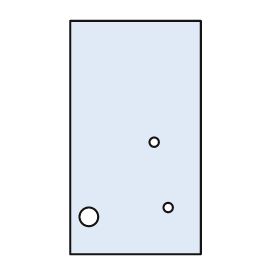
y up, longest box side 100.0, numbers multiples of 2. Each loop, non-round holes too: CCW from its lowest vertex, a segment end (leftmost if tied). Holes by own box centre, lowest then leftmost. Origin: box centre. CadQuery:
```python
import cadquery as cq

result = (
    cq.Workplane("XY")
    .moveTo(-28.0, -50.0)
    .lineTo(28.0, -50.0)
    .lineTo(28.0, 50.0)
    .lineTo(-28.0, 50.0)
    .close()
    .moveTo(-20.0, -34.0)
    .circle(4.0)
    .moveTo(14.0, -30.0)
    .circle(2.0)
    .moveTo(8.0, -2.0)
    .circle(2.0)
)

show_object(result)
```